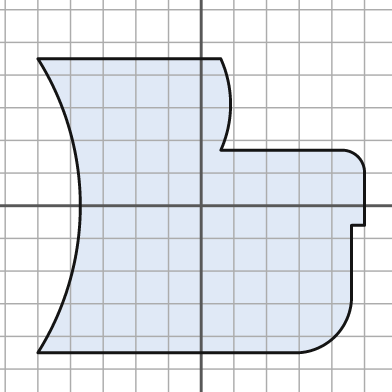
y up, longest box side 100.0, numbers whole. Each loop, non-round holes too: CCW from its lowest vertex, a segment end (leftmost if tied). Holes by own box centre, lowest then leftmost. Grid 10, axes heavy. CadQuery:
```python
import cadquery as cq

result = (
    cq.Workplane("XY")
    .moveTo(-50.0, -45.0)
    .lineTo(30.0, -45.0)
    .threePointArc((41.0, -40.0), (46.0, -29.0))
    .lineTo(46.0, -6.0)
    .lineTo(50.0, -6.0)
    .lineTo(50.0, 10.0)
    .threePointArc((48.0, 15.0), (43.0, 17.0))
    .lineTo(6.0, 17.0)
    .threePointArc((9.0, 31.0), (6.0, 45.0))
    .lineTo(-50.0, 45.0)
    .threePointArc((-37.0, 0.0), (-50.0, -45.0))
    .close()
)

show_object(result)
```